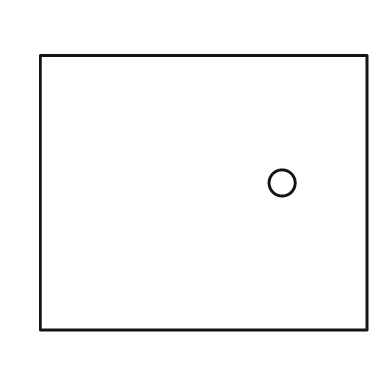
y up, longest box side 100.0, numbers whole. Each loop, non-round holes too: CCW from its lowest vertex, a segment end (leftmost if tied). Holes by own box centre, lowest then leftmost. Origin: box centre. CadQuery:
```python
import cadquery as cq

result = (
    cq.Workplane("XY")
    .moveTo(-50.0, -42.0)
    .lineTo(50.0, -42.0)
    .lineTo(50.0, 42.0)
    .lineTo(-50.0, 42.0)
    .close()
    .moveTo(24.0, 3.0)
    .circle(4.0)
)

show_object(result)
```